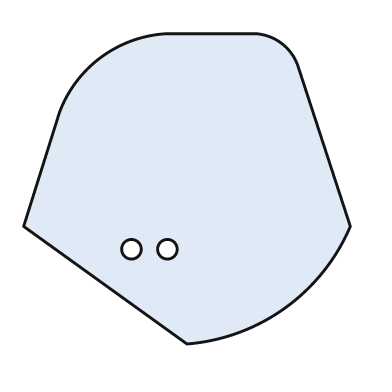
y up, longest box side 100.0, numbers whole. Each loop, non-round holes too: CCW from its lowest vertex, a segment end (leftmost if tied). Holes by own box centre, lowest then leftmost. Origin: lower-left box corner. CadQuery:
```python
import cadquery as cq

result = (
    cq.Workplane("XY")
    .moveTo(50.0, 0.0)
    .threePointArc((80.0, 11.0), (100.0, 36.0))
    .lineTo(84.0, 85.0)
    .threePointArc((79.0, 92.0), (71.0, 95.0))
    .lineTo(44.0, 95.0)
    .threePointArc((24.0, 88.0), (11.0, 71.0))
    .lineTo(0.0, 36.0)
    .close()
    .moveTo(33.0, 29.0)
    .circle(3.0)
    .moveTo(44.0, 29.0)
    .circle(3.0)
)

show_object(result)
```